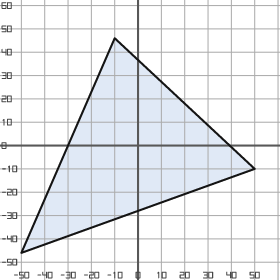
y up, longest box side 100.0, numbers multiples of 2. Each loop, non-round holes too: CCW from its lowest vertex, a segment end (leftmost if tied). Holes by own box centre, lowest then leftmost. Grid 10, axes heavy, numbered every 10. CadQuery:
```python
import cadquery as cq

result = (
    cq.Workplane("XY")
    .moveTo(-50.0, -46.0)
    .lineTo(50.0, -10.0)
    .lineTo(-10.0, 46.0)
    .close()
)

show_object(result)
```